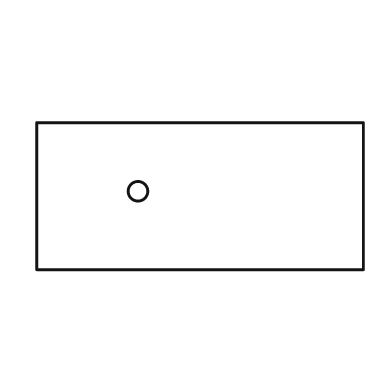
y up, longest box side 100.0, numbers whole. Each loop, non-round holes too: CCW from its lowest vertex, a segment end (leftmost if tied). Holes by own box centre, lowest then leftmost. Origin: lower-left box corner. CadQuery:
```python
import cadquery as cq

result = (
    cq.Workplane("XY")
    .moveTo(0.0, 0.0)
    .lineTo(100.0, 0.0)
    .lineTo(100.0, 45.0)
    .lineTo(0.0, 45.0)
    .close()
    .moveTo(31.0, 24.0)
    .circle(3.0)
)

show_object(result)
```